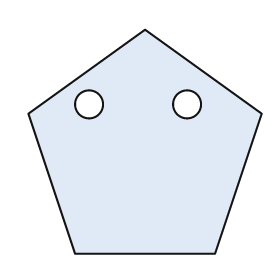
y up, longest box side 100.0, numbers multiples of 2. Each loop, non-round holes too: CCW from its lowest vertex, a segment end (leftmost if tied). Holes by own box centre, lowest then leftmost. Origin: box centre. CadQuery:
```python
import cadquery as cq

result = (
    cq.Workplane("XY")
    .moveTo(-30.0, -48.0)
    .lineTo(30.0, -48.0)
    .lineTo(50.0, 12.0)
    .lineTo(0.0, 48.0)
    .lineTo(-50.0, 12.0)
    .close()
    .moveTo(-24.0, 16.0)
    .circle(6.0)
    .moveTo(18.0, 16.0)
    .circle(6.0)
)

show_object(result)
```